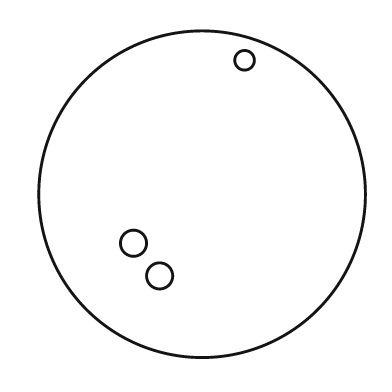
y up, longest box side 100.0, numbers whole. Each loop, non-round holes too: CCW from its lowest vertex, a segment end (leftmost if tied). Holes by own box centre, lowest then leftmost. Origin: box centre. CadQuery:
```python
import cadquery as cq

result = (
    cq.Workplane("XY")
    .moveTo(0.0, 0.0)
    .circle(50.0)
    .moveTo(-13.0, -25.0)
    .circle(4.0)
    .moveTo(-21.0, -15.0)
    .circle(4.0)
    .moveTo(13.0, 41.0)
    .circle(3.0)
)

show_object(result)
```